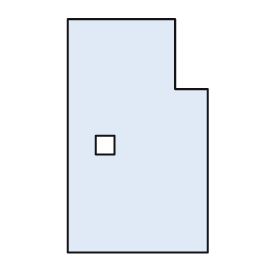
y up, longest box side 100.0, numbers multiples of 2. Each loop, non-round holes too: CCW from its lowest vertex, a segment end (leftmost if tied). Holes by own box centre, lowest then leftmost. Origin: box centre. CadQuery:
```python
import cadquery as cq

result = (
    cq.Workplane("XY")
    .moveTo(-30.0, -50.0)
    .lineTo(30.0, -50.0)
    .lineTo(30.0, 20.0)
    .lineTo(16.0, 20.0)
    .lineTo(16.0, 50.0)
    .lineTo(-30.0, 50.0)
    .close()
    .moveTo(-18.0, -8.0)
    .lineTo(-10.0, -8.0)
    .lineTo(-10.0, 0.0)
    .lineTo(-18.0, 0.0)
    .close()
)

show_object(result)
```